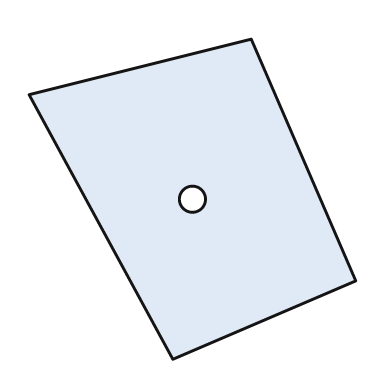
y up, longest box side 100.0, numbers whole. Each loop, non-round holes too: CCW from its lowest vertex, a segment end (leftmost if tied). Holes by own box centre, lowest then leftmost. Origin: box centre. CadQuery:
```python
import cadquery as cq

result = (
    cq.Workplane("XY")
    .moveTo(-6.0, -49.0)
    .lineTo(50.0, -25.0)
    .lineTo(18.0, 49.0)
    .lineTo(-50.0, 32.0)
    .close()
    .moveTo(0.0, 0.0)
    .circle(4.0)
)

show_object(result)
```